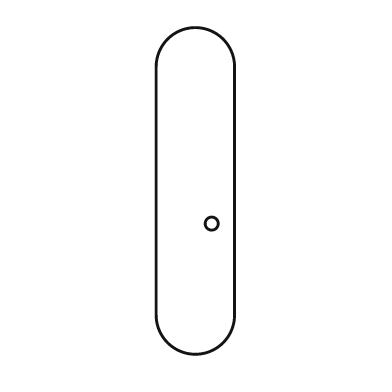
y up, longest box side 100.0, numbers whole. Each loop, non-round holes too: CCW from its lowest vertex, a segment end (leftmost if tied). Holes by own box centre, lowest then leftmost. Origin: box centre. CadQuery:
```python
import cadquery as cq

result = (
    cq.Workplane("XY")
    .moveTo(-12.0, -38.0)
    .threePointArc((0.0, -50.0), (12.0, -38.0))
    .lineTo(12.0, 38.0)
    .threePointArc((0.0, 50.0), (-12.0, 38.0))
    .close()
    .moveTo(5.0, -10.0)
    .circle(2.0)
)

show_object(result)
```